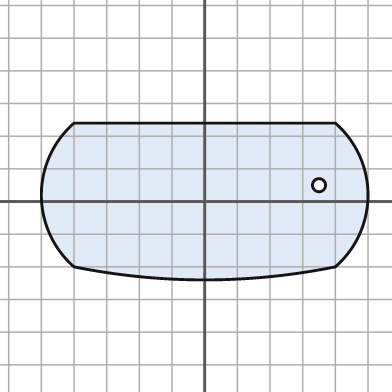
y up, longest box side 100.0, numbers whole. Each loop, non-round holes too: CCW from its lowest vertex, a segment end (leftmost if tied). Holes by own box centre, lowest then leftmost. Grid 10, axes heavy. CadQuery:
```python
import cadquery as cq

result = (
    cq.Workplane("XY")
    .moveTo(-40.0, -20.0)
    .threePointArc((0.0, -24.0), (40.0, -20.0))
    .threePointArc((50.0, 2.0), (40.0, 24.0))
    .lineTo(-40.0, 24.0)
    .threePointArc((-50.0, 2.0), (-40.0, -20.0))
    .close()
    .moveTo(35.0, 5.0)
    .circle(2.0)
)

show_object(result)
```